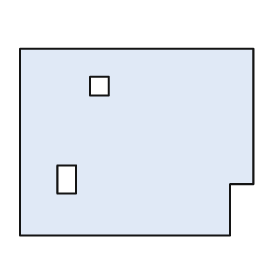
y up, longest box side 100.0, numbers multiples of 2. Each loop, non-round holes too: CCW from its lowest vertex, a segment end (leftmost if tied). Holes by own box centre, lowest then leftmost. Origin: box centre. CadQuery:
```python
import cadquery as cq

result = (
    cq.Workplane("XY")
    .moveTo(-50.0, -40.0)
    .lineTo(40.0, -40.0)
    .lineTo(40.0, -18.0)
    .lineTo(50.0, -18.0)
    .lineTo(50.0, 40.0)
    .lineTo(-50.0, 40.0)
    .close()
    .moveTo(-34.0, -22.0)
    .lineTo(-26.0, -22.0)
    .lineTo(-26.0, -10.0)
    .lineTo(-34.0, -10.0)
    .close()
    .moveTo(-20.0, 20.0)
    .lineTo(-12.0, 20.0)
    .lineTo(-12.0, 28.0)
    .lineTo(-20.0, 28.0)
    .close()
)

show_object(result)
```